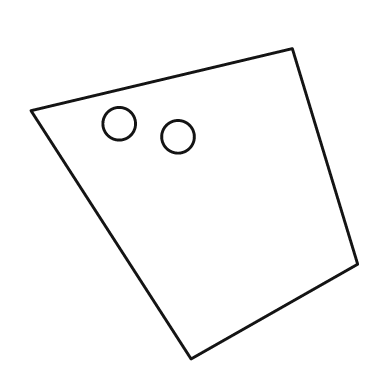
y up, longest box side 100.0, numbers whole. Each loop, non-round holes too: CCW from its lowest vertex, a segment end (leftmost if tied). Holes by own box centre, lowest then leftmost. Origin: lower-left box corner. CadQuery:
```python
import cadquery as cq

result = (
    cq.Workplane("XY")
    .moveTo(49.0, 0.0)
    .lineTo(100.0, 29.0)
    .lineTo(80.0, 95.0)
    .lineTo(0.0, 76.0)
    .close()
    .moveTo(45.0, 68.0)
    .circle(5.0)
    .moveTo(27.0, 72.0)
    .circle(5.0)
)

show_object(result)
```